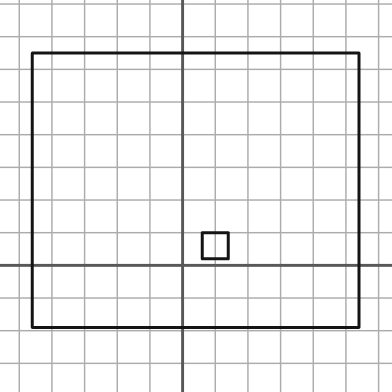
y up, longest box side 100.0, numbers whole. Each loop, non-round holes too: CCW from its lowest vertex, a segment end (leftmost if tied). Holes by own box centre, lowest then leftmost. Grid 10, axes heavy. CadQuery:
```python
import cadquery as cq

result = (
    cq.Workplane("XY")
    .moveTo(-46.0, -19.0)
    .lineTo(54.0, -19.0)
    .lineTo(54.0, 65.0)
    .lineTo(-46.0, 65.0)
    .close()
    .moveTo(6.0, 2.0)
    .lineTo(14.0, 2.0)
    .lineTo(14.0, 10.0)
    .lineTo(6.0, 10.0)
    .close()
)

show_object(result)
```